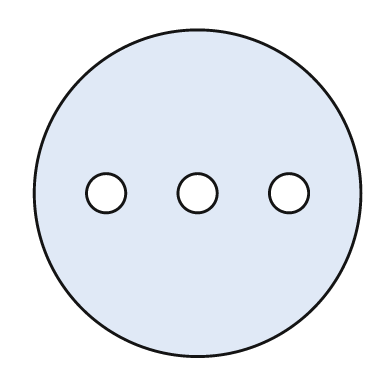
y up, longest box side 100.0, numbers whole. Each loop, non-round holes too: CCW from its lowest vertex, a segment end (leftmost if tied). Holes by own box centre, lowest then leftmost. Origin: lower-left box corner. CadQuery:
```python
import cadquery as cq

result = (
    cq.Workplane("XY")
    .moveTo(50.0, 50.0)
    .circle(50.0)
    .moveTo(22.0, 50.0)
    .circle(6.0)
    .moveTo(50.0, 50.0)
    .circle(6.0)
    .moveTo(78.0, 50.0)
    .circle(6.0)
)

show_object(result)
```